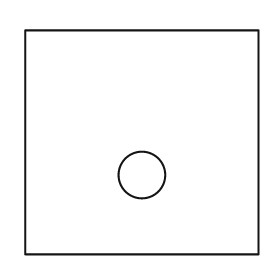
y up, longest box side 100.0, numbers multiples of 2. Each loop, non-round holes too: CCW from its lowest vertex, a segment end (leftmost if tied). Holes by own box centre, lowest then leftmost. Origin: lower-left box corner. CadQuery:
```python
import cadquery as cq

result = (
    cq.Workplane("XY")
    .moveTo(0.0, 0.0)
    .lineTo(100.0, 0.0)
    .lineTo(100.0, 96.0)
    .lineTo(0.0, 96.0)
    .close()
    .moveTo(50.0, 34.0)
    .circle(10.0)
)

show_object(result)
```